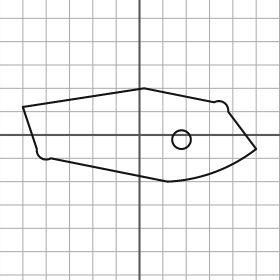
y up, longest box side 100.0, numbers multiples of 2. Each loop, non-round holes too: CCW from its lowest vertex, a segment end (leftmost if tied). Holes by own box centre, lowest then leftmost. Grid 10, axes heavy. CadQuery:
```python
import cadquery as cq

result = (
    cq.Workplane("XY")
    .moveTo(12.0, -20.0)
    .threePointArc((32.0, -16.0), (50.0, -6.0))
    .lineTo(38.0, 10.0)
    .threePointArc((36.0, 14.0), (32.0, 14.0))
    .lineTo(2.0, 20.0)
    .lineTo(-50.0, 12.0)
    .lineTo(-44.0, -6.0)
    .threePointArc((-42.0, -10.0), (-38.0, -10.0))
    .close()
    .moveTo(18.0, -2.0)
    .circle(4.0)
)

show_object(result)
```